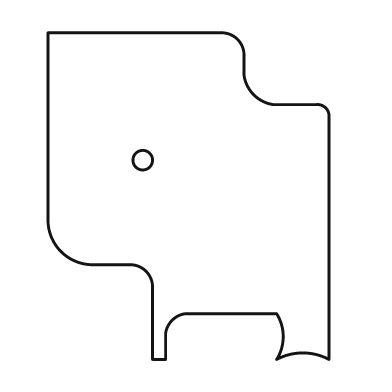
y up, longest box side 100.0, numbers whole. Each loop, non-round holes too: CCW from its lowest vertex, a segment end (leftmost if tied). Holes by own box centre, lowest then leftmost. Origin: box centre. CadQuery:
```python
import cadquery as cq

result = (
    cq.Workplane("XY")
    .moveTo(-11.0, -50.0)
    .lineTo(-7.0, -50.0)
    .lineTo(-7.0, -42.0)
    .threePointArc((-5.0, -38.0), (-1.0, -36.0))
    .lineTo(27.0, -36.0)
    .threePointArc((29.0, -43.0), (27.0, -50.0))
    .threePointArc((35.0, -48.0), (43.0, -50.0))
    .lineTo(43.0, 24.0)
    .threePointArc((42.0, 27.0), (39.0, 28.0))
    .lineTo(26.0, 28.0)
    .threePointArc((20.0, 31.0), (17.0, 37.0))
    .lineTo(17.0, 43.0)
    .threePointArc((15.0, 48.0), (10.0, 50.0))
    .lineTo(-43.0, 50.0)
    .lineTo(-43.0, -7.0)
    .threePointArc((-39.0, -17.0), (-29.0, -21.0))
    .lineTo(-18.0, -21.0)
    .threePointArc((-13.0, -23.0), (-11.0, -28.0))
    .close()
    .moveTo(-14.0, 11.0)
    .circle(3.0)
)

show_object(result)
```